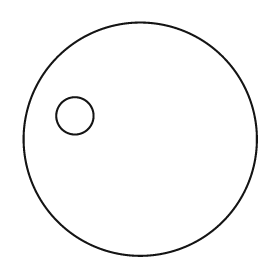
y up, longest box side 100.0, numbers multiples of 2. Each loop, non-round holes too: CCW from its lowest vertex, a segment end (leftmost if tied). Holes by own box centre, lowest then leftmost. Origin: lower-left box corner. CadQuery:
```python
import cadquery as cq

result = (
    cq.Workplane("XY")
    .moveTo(50.0, 50.0)
    .circle(50.0)
    .moveTo(22.0, 60.0)
    .circle(8.0)
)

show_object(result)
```